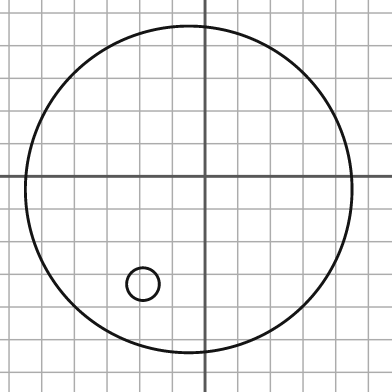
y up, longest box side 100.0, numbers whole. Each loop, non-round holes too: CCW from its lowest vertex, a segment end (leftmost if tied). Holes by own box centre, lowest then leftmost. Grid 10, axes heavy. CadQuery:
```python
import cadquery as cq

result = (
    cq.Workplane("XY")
    .moveTo(-5.0, -4.0)
    .circle(50.0)
    .moveTo(-19.0, -33.0)
    .circle(5.0)
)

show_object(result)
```